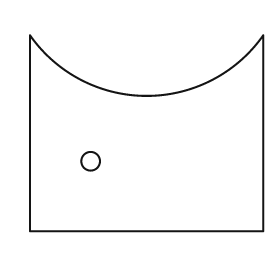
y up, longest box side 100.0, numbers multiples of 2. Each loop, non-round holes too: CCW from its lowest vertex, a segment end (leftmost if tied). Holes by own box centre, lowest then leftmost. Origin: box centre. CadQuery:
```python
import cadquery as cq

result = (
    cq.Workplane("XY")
    .moveTo(-50.0, -42.0)
    .lineTo(50.0, -42.0)
    .lineTo(50.0, 42.0)
    .threePointArc((0.0, 16.0), (-50.0, 42.0))
    .close()
    .moveTo(-24.0, -12.0)
    .circle(4.0)
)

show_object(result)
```